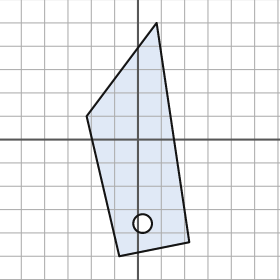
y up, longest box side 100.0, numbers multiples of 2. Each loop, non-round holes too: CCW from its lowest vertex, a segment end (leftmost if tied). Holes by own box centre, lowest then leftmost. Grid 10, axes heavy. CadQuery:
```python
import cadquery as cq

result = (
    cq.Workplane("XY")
    .moveTo(-8.0, -50.0)
    .lineTo(22.0, -44.0)
    .lineTo(8.0, 50.0)
    .lineTo(-22.0, 10.0)
    .close()
    .moveTo(2.0, -36.0)
    .circle(4.0)
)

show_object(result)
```